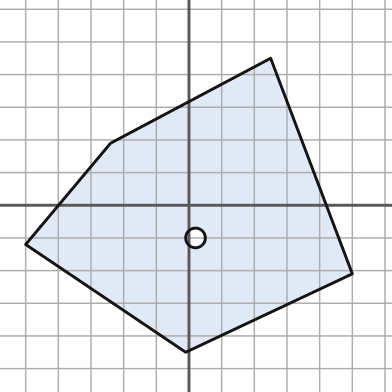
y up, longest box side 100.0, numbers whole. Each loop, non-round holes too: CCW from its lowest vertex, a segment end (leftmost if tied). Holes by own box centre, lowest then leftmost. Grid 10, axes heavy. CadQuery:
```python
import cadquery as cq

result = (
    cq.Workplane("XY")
    .moveTo(-1.0, -45.0)
    .lineTo(50.0, -21.0)
    .lineTo(25.0, 45.0)
    .lineTo(-24.0, 19.0)
    .lineTo(-50.0, -12.0)
    .close()
    .moveTo(2.0, -10.0)
    .circle(3.0)
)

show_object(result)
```